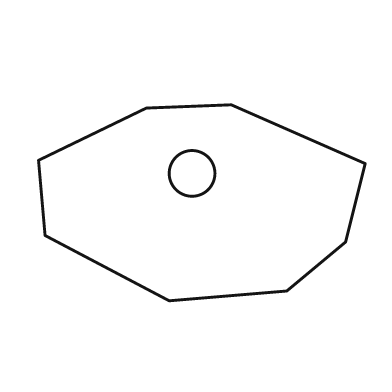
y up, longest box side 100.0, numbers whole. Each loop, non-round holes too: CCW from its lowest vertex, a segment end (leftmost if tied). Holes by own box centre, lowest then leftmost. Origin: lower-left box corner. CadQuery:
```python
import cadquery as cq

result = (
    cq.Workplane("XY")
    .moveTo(40.0, 0.0)
    .lineTo(76.0, 3.0)
    .lineTo(94.0, 18.0)
    .lineTo(100.0, 42.0)
    .lineTo(59.0, 60.0)
    .lineTo(33.0, 59.0)
    .lineTo(0.0, 43.0)
    .lineTo(2.0, 20.0)
    .close()
    .moveTo(47.0, 39.0)
    .circle(7.0)
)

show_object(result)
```